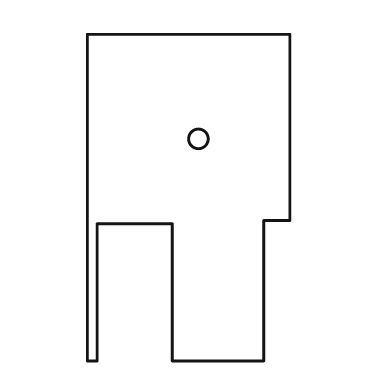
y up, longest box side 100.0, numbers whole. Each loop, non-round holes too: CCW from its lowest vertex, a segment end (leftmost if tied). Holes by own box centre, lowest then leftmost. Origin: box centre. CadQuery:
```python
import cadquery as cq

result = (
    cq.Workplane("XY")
    .moveTo(-31.0, -50.0)
    .lineTo(-28.0, -50.0)
    .lineTo(-28.0, -8.0)
    .lineTo(-5.0, -8.0)
    .lineTo(-5.0, -50.0)
    .lineTo(23.0, -50.0)
    .lineTo(23.0, -7.0)
    .lineTo(31.0, -7.0)
    .lineTo(31.0, 50.0)
    .lineTo(-31.0, 50.0)
    .close()
    .moveTo(3.0, 18.0)
    .circle(3.0)
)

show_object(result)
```